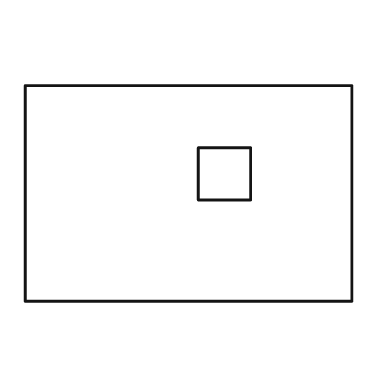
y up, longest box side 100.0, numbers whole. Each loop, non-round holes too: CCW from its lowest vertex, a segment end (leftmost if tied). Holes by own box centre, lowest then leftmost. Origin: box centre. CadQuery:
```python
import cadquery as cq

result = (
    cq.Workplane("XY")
    .moveTo(-50.0, -33.0)
    .lineTo(50.0, -33.0)
    .lineTo(50.0, 33.0)
    .lineTo(-50.0, 33.0)
    .close()
    .moveTo(3.0, -2.0)
    .lineTo(19.0, -2.0)
    .lineTo(19.0, 14.0)
    .lineTo(3.0, 14.0)
    .close()
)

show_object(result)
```